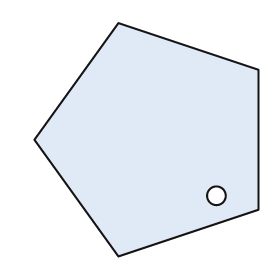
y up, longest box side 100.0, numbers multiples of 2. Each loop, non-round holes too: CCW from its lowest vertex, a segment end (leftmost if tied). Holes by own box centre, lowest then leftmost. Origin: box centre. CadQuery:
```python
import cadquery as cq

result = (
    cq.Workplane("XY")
    .moveTo(-12.0, -50.0)
    .lineTo(48.0, -30.0)
    .lineTo(48.0, 30.0)
    .lineTo(-12.0, 50.0)
    .lineTo(-48.0, 0.0)
    .close()
    .moveTo(30.0, -24.0)
    .circle(4.0)
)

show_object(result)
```